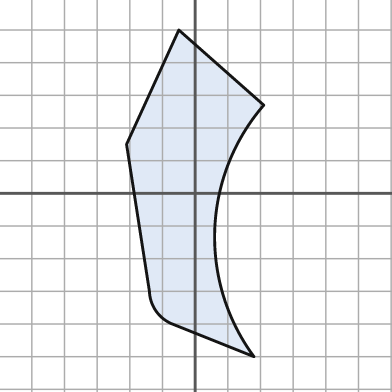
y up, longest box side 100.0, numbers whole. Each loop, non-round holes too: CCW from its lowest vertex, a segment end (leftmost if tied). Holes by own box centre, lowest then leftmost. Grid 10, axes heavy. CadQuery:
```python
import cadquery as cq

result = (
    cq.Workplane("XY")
    .moveTo(18.0, -50.0)
    .threePointArc((6.0, -11.0), (21.0, 27.0))
    .lineTo(-5.0, 50.0)
    .lineTo(-21.0, 15.0)
    .lineTo(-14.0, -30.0)
    .threePointArc((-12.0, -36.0), (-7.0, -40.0))
    .close()
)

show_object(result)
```